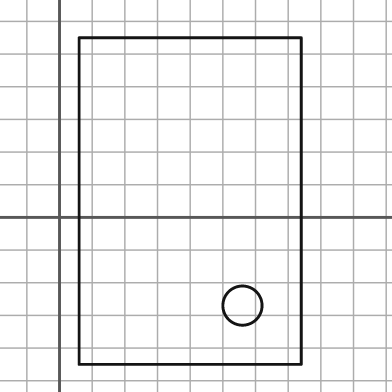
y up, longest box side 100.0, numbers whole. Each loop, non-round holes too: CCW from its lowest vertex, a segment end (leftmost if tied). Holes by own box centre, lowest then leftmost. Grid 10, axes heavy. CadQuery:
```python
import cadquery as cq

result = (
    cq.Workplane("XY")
    .moveTo(6.0, -45.0)
    .lineTo(74.0, -45.0)
    .lineTo(74.0, 55.0)
    .lineTo(6.0, 55.0)
    .close()
    .moveTo(56.0, -27.0)
    .circle(6.0)
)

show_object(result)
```